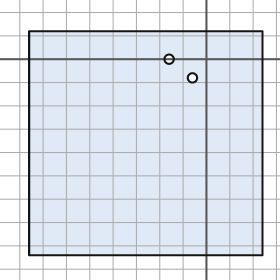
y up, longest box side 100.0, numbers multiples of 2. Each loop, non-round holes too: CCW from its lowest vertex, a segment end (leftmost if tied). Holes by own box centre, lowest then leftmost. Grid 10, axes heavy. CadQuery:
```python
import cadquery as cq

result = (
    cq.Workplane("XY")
    .moveTo(-76.0, -84.0)
    .lineTo(24.0, -84.0)
    .lineTo(24.0, 12.0)
    .lineTo(-76.0, 12.0)
    .close()
    .moveTo(-6.0, -8.0)
    .circle(2.0)
    .moveTo(-16.0, 0.0)
    .circle(2.0)
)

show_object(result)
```